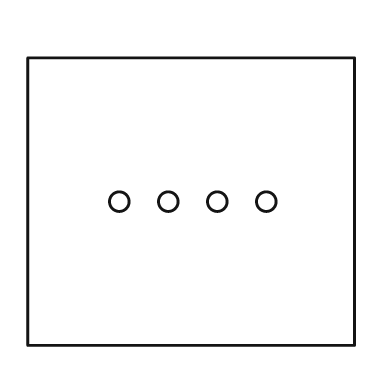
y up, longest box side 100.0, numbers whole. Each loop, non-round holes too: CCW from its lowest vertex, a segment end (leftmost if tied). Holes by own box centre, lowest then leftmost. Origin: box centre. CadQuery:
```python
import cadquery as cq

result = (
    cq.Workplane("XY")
    .moveTo(-50.0, -44.0)
    .lineTo(50.0, -44.0)
    .lineTo(50.0, 44.0)
    .lineTo(-50.0, 44.0)
    .close()
    .moveTo(-22.0, 0.0)
    .circle(3.0)
    .moveTo(-7.0, 0.0)
    .circle(3.0)
    .moveTo(8.0, 0.0)
    .circle(3.0)
    .moveTo(23.0, 0.0)
    .circle(3.0)
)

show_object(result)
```